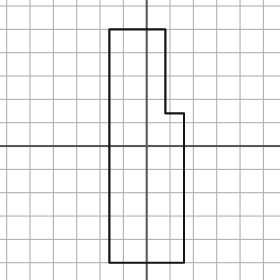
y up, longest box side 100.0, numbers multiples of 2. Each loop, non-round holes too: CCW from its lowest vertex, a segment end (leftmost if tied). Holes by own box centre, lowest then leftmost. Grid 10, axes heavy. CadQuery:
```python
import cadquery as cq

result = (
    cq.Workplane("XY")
    .moveTo(-16.0, -50.0)
    .lineTo(16.0, -50.0)
    .lineTo(16.0, 14.0)
    .lineTo(8.0, 14.0)
    .lineTo(8.0, 50.0)
    .lineTo(-16.0, 50.0)
    .close()
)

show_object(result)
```